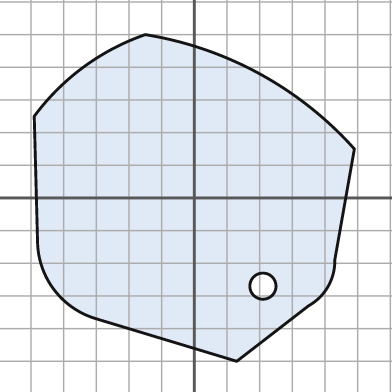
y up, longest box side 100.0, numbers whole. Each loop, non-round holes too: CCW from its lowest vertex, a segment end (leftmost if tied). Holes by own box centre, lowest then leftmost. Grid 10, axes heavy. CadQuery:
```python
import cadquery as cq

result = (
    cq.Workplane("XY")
    .moveTo(13.0, -50.0)
    .lineTo(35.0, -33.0)
    .threePointArc((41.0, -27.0), (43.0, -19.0))
    .lineTo(49.0, 15.0)
    .threePointArc((20.0, 38.0), (-15.0, 50.0))
    .threePointArc((-34.0, 40.0), (-49.0, 25.0))
    .lineTo(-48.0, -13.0)
    .threePointArc((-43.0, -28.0), (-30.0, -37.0))
    .close()
    .moveTo(21.0, -27.0)
    .circle(4.0)
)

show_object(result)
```